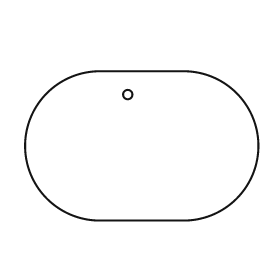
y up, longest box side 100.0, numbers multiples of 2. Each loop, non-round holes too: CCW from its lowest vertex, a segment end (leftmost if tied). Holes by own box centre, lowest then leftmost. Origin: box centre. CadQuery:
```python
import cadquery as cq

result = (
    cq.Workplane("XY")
    .moveTo(-18.0, -32.0)
    .lineTo(18.0, -32.0)
    .threePointArc((50.0, 0.0), (18.0, 32.0))
    .lineTo(-18.0, 32.0)
    .threePointArc((-50.0, 0.0), (-18.0, -32.0))
    .close()
    .moveTo(-6.0, 22.0)
    .circle(2.0)
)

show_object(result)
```